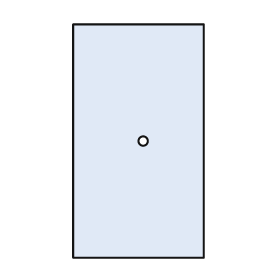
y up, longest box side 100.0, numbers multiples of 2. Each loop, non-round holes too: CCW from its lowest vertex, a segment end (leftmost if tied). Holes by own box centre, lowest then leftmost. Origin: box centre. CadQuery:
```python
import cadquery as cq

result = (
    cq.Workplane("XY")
    .moveTo(-28.0, -50.0)
    .lineTo(28.0, -50.0)
    .lineTo(28.0, 50.0)
    .lineTo(-28.0, 50.0)
    .close()
    .moveTo(2.0, 0.0)
    .circle(2.0)
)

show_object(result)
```